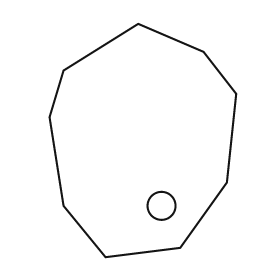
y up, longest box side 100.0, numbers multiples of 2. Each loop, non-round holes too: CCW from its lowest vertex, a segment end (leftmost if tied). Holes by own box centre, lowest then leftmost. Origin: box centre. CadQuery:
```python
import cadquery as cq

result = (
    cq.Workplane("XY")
    .moveTo(-16.0, -50.0)
    .lineTo(16.0, -46.0)
    .lineTo(36.0, -18.0)
    .lineTo(40.0, 20.0)
    .lineTo(26.0, 38.0)
    .lineTo(-2.0, 50.0)
    .lineTo(-34.0, 30.0)
    .lineTo(-40.0, 10.0)
    .lineTo(-34.0, -28.0)
    .close()
    .moveTo(8.0, -28.0)
    .circle(6.0)
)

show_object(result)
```